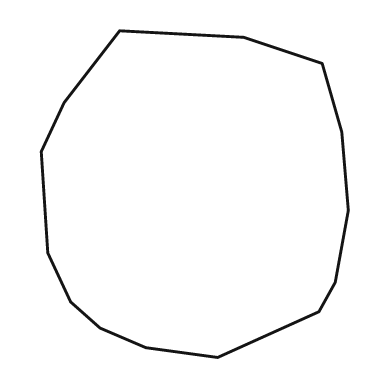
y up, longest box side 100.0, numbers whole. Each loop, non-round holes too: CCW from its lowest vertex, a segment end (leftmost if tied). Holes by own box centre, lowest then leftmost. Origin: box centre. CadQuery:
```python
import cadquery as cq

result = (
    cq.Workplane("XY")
    .moveTo(7.0, -50.0)
    .lineTo(38.0, -36.0)
    .lineTo(43.0, -27.0)
    .lineTo(47.0, -5.0)
    .lineTo(45.0, 19.0)
    .lineTo(39.0, 40.0)
    .lineTo(15.0, 48.0)
    .lineTo(-23.0, 50.0)
    .lineTo(-40.0, 28.0)
    .lineTo(-47.0, 13.0)
    .lineTo(-45.0, -18.0)
    .lineTo(-38.0, -33.0)
    .lineTo(-29.0, -41.0)
    .lineTo(-15.0, -47.0)
    .close()
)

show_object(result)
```